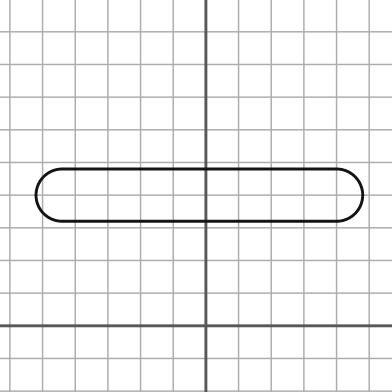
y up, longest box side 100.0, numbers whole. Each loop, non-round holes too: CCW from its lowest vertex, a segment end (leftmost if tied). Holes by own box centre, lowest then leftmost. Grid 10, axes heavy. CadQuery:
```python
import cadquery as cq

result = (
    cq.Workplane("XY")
    .moveTo(-44.0, 32.0)
    .lineTo(40.0, 32.0)
    .threePointArc((48.0, 40.0), (40.0, 48.0))
    .lineTo(-44.0, 48.0)
    .threePointArc((-52.0, 40.0), (-44.0, 32.0))
    .close()
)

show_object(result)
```